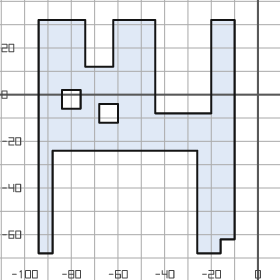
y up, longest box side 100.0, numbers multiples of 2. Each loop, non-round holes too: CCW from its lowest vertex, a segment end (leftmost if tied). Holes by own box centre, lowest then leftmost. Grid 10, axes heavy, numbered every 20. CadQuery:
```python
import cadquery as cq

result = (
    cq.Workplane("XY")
    .moveTo(-94.0, -68.0)
    .lineTo(-88.0, -68.0)
    .lineTo(-88.0, -24.0)
    .lineTo(-26.0, -24.0)
    .lineTo(-26.0, -68.0)
    .lineTo(-16.0, -68.0)
    .lineTo(-16.0, -62.0)
    .lineTo(-10.0, -62.0)
    .lineTo(-10.0, 32.0)
    .lineTo(-20.0, 32.0)
    .lineTo(-20.0, -8.0)
    .lineTo(-44.0, -8.0)
    .lineTo(-44.0, 32.0)
    .lineTo(-62.0, 32.0)
    .lineTo(-62.0, 12.0)
    .lineTo(-74.0, 12.0)
    .lineTo(-74.0, 32.0)
    .lineTo(-94.0, 32.0)
    .close()
    .moveTo(-68.0, -12.0)
    .lineTo(-60.0, -12.0)
    .lineTo(-60.0, -4.0)
    .lineTo(-68.0, -4.0)
    .close()
    .moveTo(-84.0, -6.0)
    .lineTo(-76.0, -6.0)
    .lineTo(-76.0, 2.0)
    .lineTo(-84.0, 2.0)
    .close()
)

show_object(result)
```